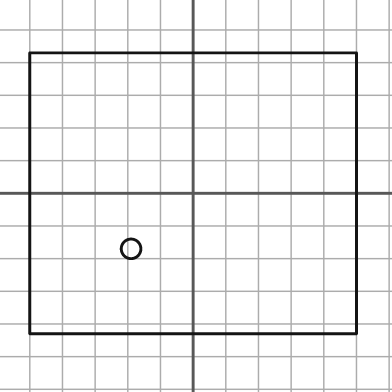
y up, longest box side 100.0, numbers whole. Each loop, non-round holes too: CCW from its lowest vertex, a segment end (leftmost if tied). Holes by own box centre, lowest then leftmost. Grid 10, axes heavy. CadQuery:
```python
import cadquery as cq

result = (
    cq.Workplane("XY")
    .moveTo(-50.0, -43.0)
    .lineTo(50.0, -43.0)
    .lineTo(50.0, 43.0)
    .lineTo(-50.0, 43.0)
    .close()
    .moveTo(-19.0, -17.0)
    .circle(3.0)
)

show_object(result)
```